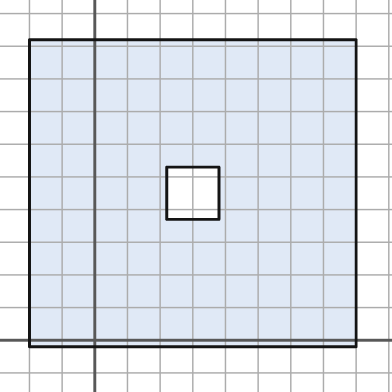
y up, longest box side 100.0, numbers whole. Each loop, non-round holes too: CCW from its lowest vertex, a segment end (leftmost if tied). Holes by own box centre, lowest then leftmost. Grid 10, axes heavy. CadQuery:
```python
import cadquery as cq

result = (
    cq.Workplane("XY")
    .moveTo(-20.0, -2.0)
    .lineTo(80.0, -2.0)
    .lineTo(80.0, 92.0)
    .lineTo(-20.0, 92.0)
    .close()
    .moveTo(22.0, 37.0)
    .lineTo(38.0, 37.0)
    .lineTo(38.0, 53.0)
    .lineTo(22.0, 53.0)
    .close()
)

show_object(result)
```